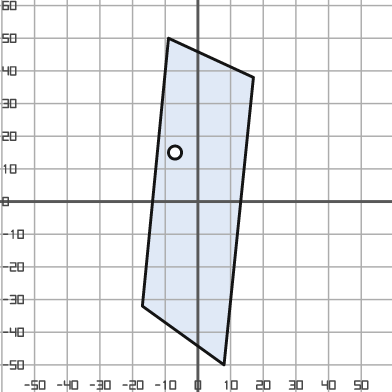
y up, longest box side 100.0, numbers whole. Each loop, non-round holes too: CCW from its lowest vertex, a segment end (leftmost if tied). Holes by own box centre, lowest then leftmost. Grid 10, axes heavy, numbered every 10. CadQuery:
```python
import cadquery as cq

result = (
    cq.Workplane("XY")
    .moveTo(8.0, -50.0)
    .lineTo(17.0, 38.0)
    .lineTo(-9.0, 50.0)
    .lineTo(-17.0, -32.0)
    .close()
    .moveTo(-7.0, 15.0)
    .circle(2.0)
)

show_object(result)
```